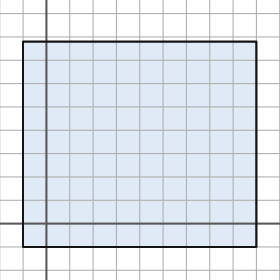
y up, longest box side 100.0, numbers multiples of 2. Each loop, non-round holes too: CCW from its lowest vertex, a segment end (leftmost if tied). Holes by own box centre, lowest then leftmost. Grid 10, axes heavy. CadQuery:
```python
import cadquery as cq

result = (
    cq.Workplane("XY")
    .moveTo(-10.0, -10.0)
    .lineTo(90.0, -10.0)
    .lineTo(90.0, 78.0)
    .lineTo(-10.0, 78.0)
    .close()
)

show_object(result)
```